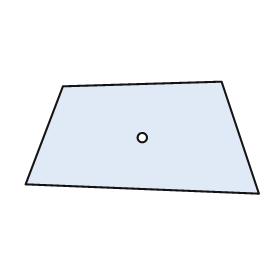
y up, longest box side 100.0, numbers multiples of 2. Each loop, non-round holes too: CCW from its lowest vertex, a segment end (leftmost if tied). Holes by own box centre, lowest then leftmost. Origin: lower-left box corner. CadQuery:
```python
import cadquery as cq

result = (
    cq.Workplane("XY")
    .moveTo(100.0, 0.0)
    .lineTo(84.0, 48.0)
    .lineTo(16.0, 46.0)
    .lineTo(0.0, 4.0)
    .close()
    .moveTo(50.0, 24.0)
    .circle(2.0)
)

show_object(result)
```